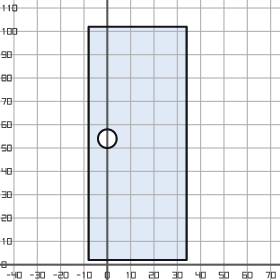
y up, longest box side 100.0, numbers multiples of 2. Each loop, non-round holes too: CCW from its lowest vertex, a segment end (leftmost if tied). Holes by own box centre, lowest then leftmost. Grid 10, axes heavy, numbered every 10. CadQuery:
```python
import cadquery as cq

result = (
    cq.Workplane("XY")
    .moveTo(-8.0, 2.0)
    .lineTo(34.0, 2.0)
    .lineTo(34.0, 102.0)
    .lineTo(-8.0, 102.0)
    .close()
    .moveTo(0.0, 54.0)
    .circle(4.0)
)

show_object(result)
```